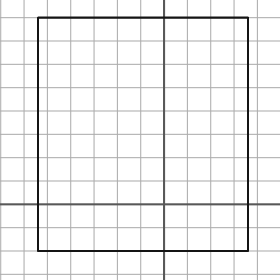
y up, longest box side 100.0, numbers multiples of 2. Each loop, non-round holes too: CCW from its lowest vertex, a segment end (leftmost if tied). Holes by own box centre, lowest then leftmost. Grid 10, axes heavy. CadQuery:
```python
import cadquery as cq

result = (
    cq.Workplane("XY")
    .moveTo(-54.0, -20.0)
    .lineTo(36.0, -20.0)
    .lineTo(36.0, 80.0)
    .lineTo(-54.0, 80.0)
    .close()
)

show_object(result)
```